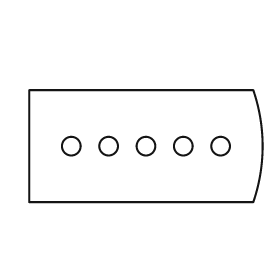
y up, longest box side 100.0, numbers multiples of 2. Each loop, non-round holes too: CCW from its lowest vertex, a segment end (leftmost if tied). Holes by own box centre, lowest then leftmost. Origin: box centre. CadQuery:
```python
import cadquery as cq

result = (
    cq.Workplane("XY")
    .moveTo(-50.0, -24.0)
    .lineTo(46.0, -24.0)
    .threePointArc((50.0, 0.0), (46.0, 24.0))
    .lineTo(-50.0, 24.0)
    .close()
    .moveTo(-32.0, 0.0)
    .circle(4.0)
    .moveTo(-16.0, 0.0)
    .circle(4.0)
    .moveTo(0.0, 0.0)
    .circle(4.0)
    .moveTo(16.0, 0.0)
    .circle(4.0)
    .moveTo(32.0, 0.0)
    .circle(4.0)
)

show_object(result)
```